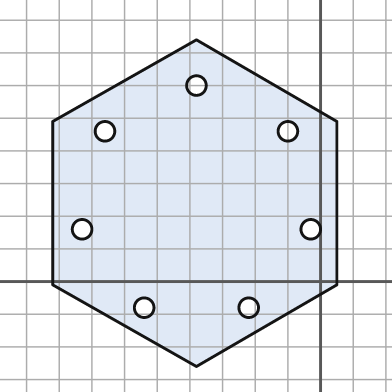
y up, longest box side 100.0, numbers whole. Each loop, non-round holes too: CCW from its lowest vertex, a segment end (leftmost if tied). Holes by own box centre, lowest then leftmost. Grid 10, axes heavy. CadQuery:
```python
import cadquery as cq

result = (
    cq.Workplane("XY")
    .moveTo(-38.0, -26.0)
    .lineTo(5.0, -1.0)
    .lineTo(5.0, 49.0)
    .lineTo(-38.0, 74.0)
    .lineTo(-82.0, 49.0)
    .lineTo(-82.0, -1.0)
    .close()
    .moveTo(-54.0, -8.0)
    .circle(3.0)
    .moveTo(-22.0, -8.0)
    .circle(3.0)
    .moveTo(-73.0, 16.0)
    .circle(3.0)
    .moveTo(-3.0, 16.0)
    .circle(3.0)
    .moveTo(-66.0, 46.0)
    .circle(3.0)
    .moveTo(-10.0, 46.0)
    .circle(3.0)
    .moveTo(-38.0, 60.0)
    .circle(3.0)
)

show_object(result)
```